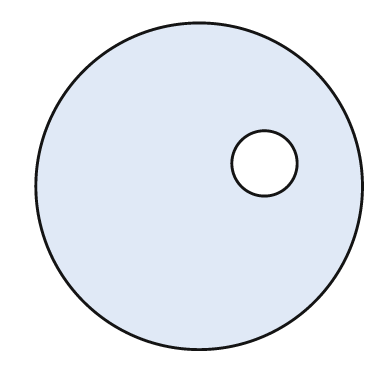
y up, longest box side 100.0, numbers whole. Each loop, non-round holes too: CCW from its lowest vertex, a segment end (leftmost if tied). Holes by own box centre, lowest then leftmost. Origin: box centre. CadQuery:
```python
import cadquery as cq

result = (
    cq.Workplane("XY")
    .moveTo(0.0, 0.0)
    .circle(50.0)
    .moveTo(20.0, 7.0)
    .circle(10.0)
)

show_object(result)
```